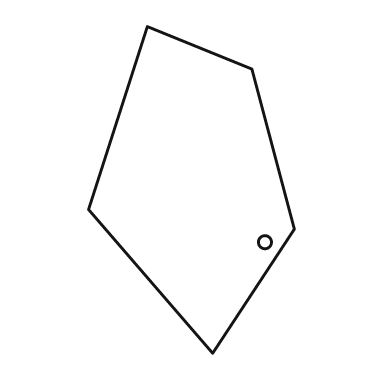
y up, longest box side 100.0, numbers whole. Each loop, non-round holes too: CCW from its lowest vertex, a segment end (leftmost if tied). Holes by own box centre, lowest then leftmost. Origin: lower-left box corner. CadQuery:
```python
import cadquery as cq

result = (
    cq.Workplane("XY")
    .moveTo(38.0, 0.0)
    .lineTo(63.0, 38.0)
    .lineTo(50.0, 87.0)
    .lineTo(18.0, 100.0)
    .lineTo(0.0, 44.0)
    .close()
    .moveTo(54.0, 34.0)
    .circle(2.0)
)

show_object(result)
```